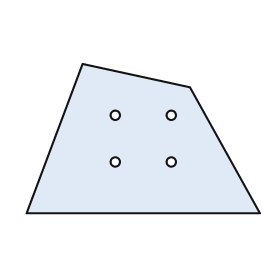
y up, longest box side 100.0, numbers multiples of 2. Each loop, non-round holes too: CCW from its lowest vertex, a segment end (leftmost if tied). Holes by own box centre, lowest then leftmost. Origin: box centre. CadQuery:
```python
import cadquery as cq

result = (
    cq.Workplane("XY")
    .moveTo(-50.0, -32.0)
    .lineTo(50.0, -32.0)
    .lineTo(20.0, 22.0)
    .lineTo(-26.0, 32.0)
    .close()
    .moveTo(-12.0, -10.0)
    .circle(2.0)
    .moveTo(12.0, -10.0)
    .circle(2.0)
    .moveTo(-12.0, 10.0)
    .circle(2.0)
    .moveTo(12.0, 10.0)
    .circle(2.0)
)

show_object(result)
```